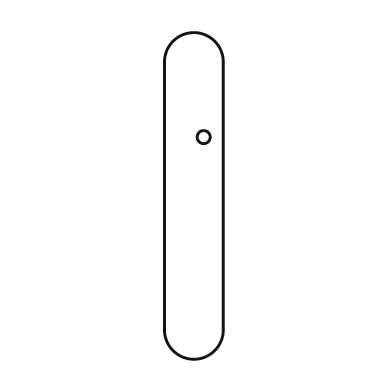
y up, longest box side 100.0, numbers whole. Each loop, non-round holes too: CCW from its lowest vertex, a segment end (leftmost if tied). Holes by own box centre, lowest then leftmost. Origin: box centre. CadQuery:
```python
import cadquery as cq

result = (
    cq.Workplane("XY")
    .moveTo(-9.0, -41.0)
    .threePointArc((0.0, -50.0), (9.0, -41.0))
    .lineTo(9.0, 41.0)
    .threePointArc((0.0, 50.0), (-9.0, 41.0))
    .close()
    .moveTo(3.0, 18.0)
    .circle(2.0)
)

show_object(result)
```